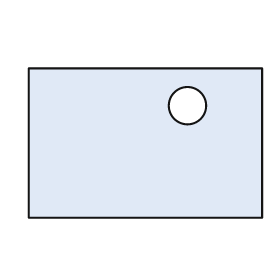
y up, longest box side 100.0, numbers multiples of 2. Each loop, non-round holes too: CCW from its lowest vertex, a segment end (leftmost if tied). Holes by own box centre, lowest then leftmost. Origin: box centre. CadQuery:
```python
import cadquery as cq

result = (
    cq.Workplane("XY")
    .moveTo(-50.0, -32.0)
    .lineTo(50.0, -32.0)
    .lineTo(50.0, 32.0)
    .lineTo(-50.0, 32.0)
    .close()
    .moveTo(18.0, 16.0)
    .circle(8.0)
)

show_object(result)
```